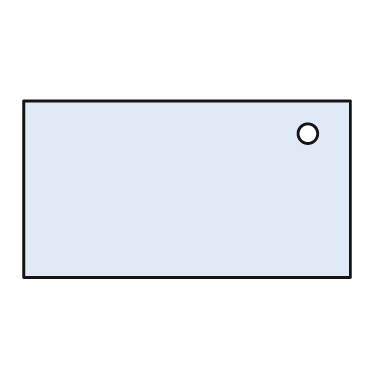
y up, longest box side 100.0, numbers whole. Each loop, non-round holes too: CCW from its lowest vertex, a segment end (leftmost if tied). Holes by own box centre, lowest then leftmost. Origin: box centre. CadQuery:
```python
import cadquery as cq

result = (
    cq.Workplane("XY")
    .moveTo(-50.0, -27.0)
    .lineTo(50.0, -27.0)
    .lineTo(50.0, 27.0)
    .lineTo(-50.0, 27.0)
    .close()
    .moveTo(37.0, 17.0)
    .circle(3.0)
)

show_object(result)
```